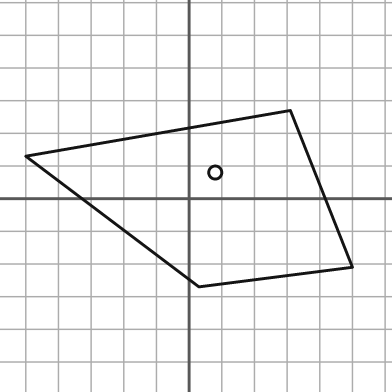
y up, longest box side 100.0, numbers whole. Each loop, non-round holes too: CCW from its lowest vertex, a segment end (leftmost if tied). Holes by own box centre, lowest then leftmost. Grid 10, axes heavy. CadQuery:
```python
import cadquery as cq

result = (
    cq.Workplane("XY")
    .moveTo(3.0, -27.0)
    .lineTo(50.0, -21.0)
    .lineTo(31.0, 27.0)
    .lineTo(-50.0, 13.0)
    .close()
    .moveTo(8.0, 8.0)
    .circle(2.0)
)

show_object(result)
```